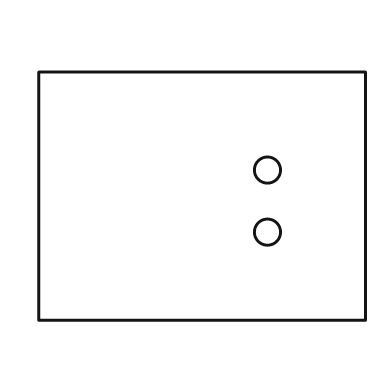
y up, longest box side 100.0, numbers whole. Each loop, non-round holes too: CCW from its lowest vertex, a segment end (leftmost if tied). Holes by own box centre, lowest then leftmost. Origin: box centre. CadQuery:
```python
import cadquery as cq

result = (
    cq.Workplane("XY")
    .moveTo(-50.0, -38.0)
    .lineTo(50.0, -38.0)
    .lineTo(50.0, 38.0)
    .lineTo(-50.0, 38.0)
    .close()
    .moveTo(20.0, -11.0)
    .circle(4.0)
    .moveTo(20.0, 8.0)
    .circle(4.0)
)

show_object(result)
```